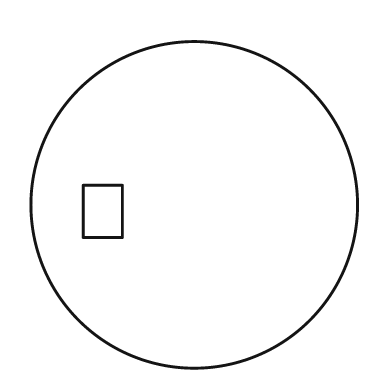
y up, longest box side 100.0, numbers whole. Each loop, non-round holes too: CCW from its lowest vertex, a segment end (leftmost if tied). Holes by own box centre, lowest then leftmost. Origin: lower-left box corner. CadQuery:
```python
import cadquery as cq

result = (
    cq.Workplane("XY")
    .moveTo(50.0, 50.0)
    .circle(50.0)
    .moveTo(16.0, 40.0)
    .lineTo(28.0, 40.0)
    .lineTo(28.0, 56.0)
    .lineTo(16.0, 56.0)
    .close()
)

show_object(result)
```